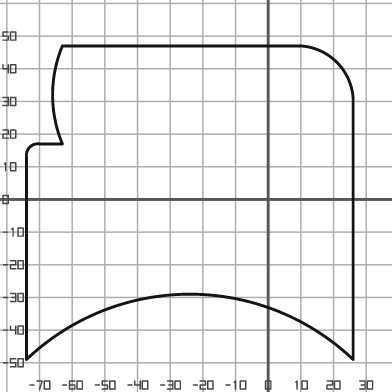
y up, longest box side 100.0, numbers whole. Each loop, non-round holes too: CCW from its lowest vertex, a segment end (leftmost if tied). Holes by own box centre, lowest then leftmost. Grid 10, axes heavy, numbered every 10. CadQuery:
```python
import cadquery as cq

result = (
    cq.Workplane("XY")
    .moveTo(-74.0, -49.0)
    .threePointArc((-24.0, -29.0), (26.0, -49.0))
    .lineTo(26.0, 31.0)
    .threePointArc((21.0, 42.0), (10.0, 47.0))
    .lineTo(-63.0, 47.0)
    .threePointArc((-66.0, 32.0), (-63.0, 17.0))
    .lineTo(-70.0, 17.0)
    .threePointArc((-73.0, 16.0), (-74.0, 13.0))
    .close()
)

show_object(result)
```